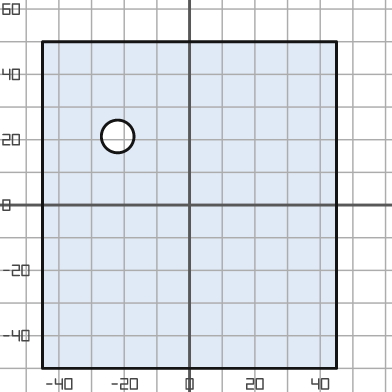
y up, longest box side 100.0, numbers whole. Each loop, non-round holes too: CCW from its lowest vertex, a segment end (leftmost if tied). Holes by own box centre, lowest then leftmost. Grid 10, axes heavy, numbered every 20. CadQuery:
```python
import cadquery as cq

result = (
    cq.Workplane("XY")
    .moveTo(-45.0, -50.0)
    .lineTo(45.0, -50.0)
    .lineTo(45.0, 50.0)
    .lineTo(-45.0, 50.0)
    .close()
    .moveTo(-22.0, 21.0)
    .circle(5.0)
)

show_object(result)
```